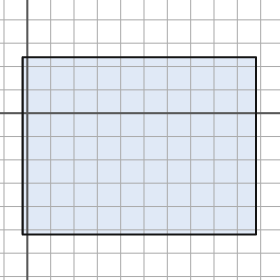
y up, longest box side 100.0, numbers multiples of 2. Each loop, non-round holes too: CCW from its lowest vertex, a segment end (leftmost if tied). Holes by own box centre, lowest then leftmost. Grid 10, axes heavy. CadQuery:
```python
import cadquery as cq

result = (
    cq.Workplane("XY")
    .moveTo(-2.0, -52.0)
    .lineTo(98.0, -52.0)
    .lineTo(98.0, 24.0)
    .lineTo(-2.0, 24.0)
    .close()
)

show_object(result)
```